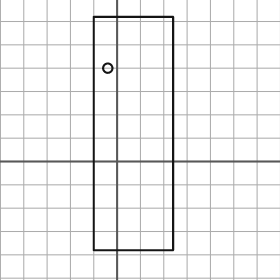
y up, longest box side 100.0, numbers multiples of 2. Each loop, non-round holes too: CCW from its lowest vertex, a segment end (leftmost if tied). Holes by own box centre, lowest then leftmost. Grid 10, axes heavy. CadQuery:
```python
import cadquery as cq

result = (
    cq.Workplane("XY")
    .moveTo(-10.0, -38.0)
    .lineTo(24.0, -38.0)
    .lineTo(24.0, 62.0)
    .lineTo(-10.0, 62.0)
    .close()
    .moveTo(-4.0, 40.0)
    .circle(2.0)
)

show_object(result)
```